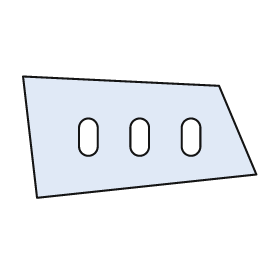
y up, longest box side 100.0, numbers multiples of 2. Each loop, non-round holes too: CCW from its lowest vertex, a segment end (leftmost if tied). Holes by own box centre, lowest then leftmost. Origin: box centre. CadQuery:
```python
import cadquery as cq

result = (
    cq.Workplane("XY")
    .moveTo(-44.0, -26.0)
    .lineTo(50.0, -16.0)
    .lineTo(34.0, 22.0)
    .lineTo(-50.0, 26.0)
    .close()
    .moveTo(-26.0, -4.0)
    .threePointArc((-22.0, -8.0), (-18.0, -4.0))
    .lineTo(-18.0, 4.0)
    .threePointArc((-22.0, 8.0), (-26.0, 4.0))
    .close()
    .moveTo(-4.0, -4.0)
    .threePointArc((0.0, -8.0), (4.0, -4.0))
    .lineTo(4.0, 4.0)
    .threePointArc((0.0, 8.0), (-4.0, 4.0))
    .close()
    .moveTo(18.0, -4.0)
    .threePointArc((22.0, -8.0), (26.0, -4.0))
    .lineTo(26.0, 4.0)
    .threePointArc((22.0, 8.0), (18.0, 4.0))
    .close()
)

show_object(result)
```